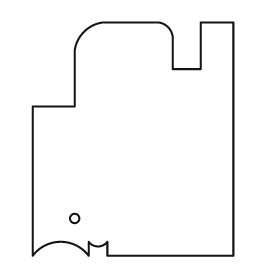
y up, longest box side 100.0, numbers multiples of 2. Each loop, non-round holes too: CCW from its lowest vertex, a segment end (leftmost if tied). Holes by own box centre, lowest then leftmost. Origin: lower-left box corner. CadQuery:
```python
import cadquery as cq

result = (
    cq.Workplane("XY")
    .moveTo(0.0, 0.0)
    .threePointArc((12.0, 6.0), (24.0, 0.0))
    .lineTo(24.0, 6.0)
    .threePointArc((28.0, 4.0), (32.0, 6.0))
    .lineTo(32.0, 0.0)
    .lineTo(86.0, 0.0)
    .lineTo(86.0, 100.0)
    .lineTo(72.0, 100.0)
    .lineTo(72.0, 80.0)
    .lineTo(60.0, 80.0)
    .lineTo(60.0, 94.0)
    .threePointArc((58.0, 98.0), (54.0, 100.0))
    .lineTo(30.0, 100.0)
    .threePointArc((22.0, 96.0), (18.0, 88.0))
    .lineTo(18.0, 64.0)
    .lineTo(0.0, 64.0)
    .close()
    .moveTo(18.0, 16.0)
    .circle(2.0)
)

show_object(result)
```